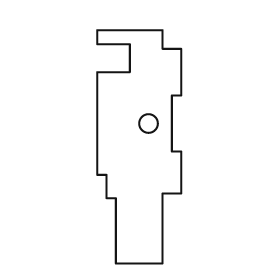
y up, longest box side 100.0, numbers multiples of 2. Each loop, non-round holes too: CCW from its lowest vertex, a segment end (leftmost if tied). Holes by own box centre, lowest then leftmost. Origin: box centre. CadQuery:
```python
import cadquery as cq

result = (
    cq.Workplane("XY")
    .moveTo(-10.0, -50.0)
    .lineTo(10.0, -50.0)
    .lineTo(10.0, -20.0)
    .lineTo(18.0, -20.0)
    .lineTo(18.0, -2.0)
    .lineTo(14.0, -2.0)
    .lineTo(14.0, 22.0)
    .lineTo(18.0, 22.0)
    .lineTo(18.0, 42.0)
    .lineTo(10.0, 42.0)
    .lineTo(10.0, 50.0)
    .lineTo(-18.0, 50.0)
    .lineTo(-18.0, 44.0)
    .lineTo(-4.0, 44.0)
    .lineTo(-4.0, 32.0)
    .lineTo(-18.0, 32.0)
    .lineTo(-18.0, -12.0)
    .lineTo(-14.0, -12.0)
    .lineTo(-14.0, -22.0)
    .lineTo(-10.0, -22.0)
    .close()
    .moveTo(4.0, 10.0)
    .circle(4.0)
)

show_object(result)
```